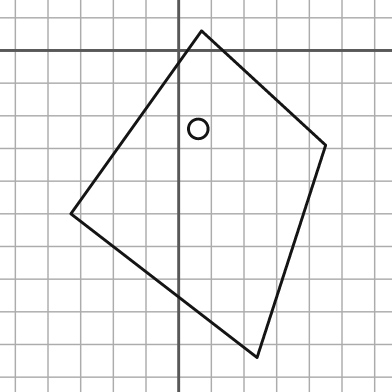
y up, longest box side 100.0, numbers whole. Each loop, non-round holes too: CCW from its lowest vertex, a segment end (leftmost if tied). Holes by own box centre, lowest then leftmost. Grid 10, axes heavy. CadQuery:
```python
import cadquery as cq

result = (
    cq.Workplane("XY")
    .moveTo(24.0, -94.0)
    .lineTo(45.0, -29.0)
    .lineTo(7.0, 6.0)
    .lineTo(-33.0, -50.0)
    .close()
    .moveTo(6.0, -24.0)
    .circle(3.0)
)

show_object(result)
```